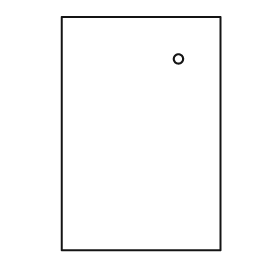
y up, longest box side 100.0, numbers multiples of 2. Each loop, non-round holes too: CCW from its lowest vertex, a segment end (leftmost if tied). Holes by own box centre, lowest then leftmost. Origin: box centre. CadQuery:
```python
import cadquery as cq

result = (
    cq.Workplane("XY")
    .moveTo(-34.0, -50.0)
    .lineTo(34.0, -50.0)
    .lineTo(34.0, 50.0)
    .lineTo(-34.0, 50.0)
    .close()
    .moveTo(16.0, 32.0)
    .circle(2.0)
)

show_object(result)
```